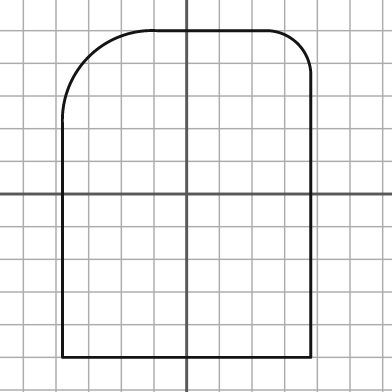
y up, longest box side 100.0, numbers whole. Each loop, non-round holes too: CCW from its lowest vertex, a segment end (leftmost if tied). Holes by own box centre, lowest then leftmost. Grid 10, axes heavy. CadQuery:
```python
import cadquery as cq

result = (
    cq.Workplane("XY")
    .moveTo(-38.0, -50.0)
    .lineTo(38.0, -50.0)
    .lineTo(38.0, 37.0)
    .threePointArc((34.0, 46.0), (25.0, 50.0))
    .lineTo(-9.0, 50.0)
    .threePointArc((-30.0, 42.0), (-38.0, 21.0))
    .close()
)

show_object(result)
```